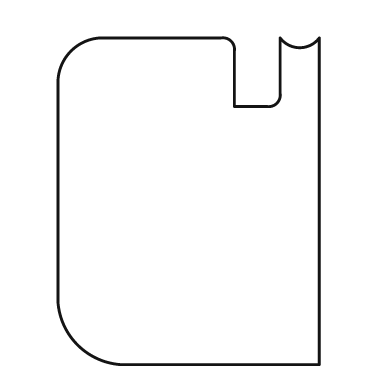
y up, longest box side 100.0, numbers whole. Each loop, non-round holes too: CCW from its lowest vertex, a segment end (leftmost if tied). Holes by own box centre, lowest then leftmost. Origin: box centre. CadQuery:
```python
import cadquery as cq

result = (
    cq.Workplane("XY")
    .moveTo(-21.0, -50.0)
    .lineTo(40.0, -50.0)
    .lineTo(40.0, 50.0)
    .threePointArc((34.0, 47.0), (28.0, 50.0))
    .lineTo(28.0, 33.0)
    .threePointArc((27.0, 30.0), (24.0, 29.0))
    .lineTo(14.0, 29.0)
    .lineTo(14.0, 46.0)
    .threePointArc((13.0, 49.0), (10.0, 50.0))
    .lineTo(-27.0, 50.0)
    .threePointArc((-36.0, 46.0), (-40.0, 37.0))
    .lineTo(-40.0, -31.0)
    .threePointArc((-34.0, -44.0), (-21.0, -50.0))
    .close()
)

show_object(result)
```